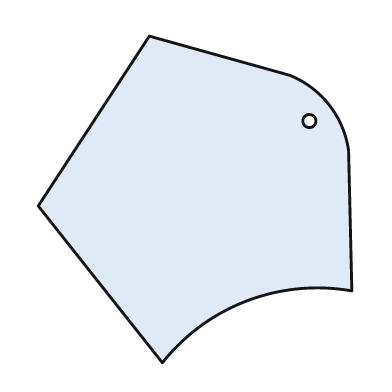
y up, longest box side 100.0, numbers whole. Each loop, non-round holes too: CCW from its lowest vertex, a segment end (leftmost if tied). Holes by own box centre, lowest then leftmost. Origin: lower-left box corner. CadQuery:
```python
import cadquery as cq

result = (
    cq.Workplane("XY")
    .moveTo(38.0, 0.0)
    .threePointArc((64.0, 19.0), (96.0, 22.0))
    .lineTo(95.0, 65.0)
    .threePointArc((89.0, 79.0), (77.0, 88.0))
    .lineTo(34.0, 100.0)
    .lineTo(0.0, 48.0)
    .close()
    .moveTo(83.0, 74.0)
    .circle(2.0)
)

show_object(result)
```